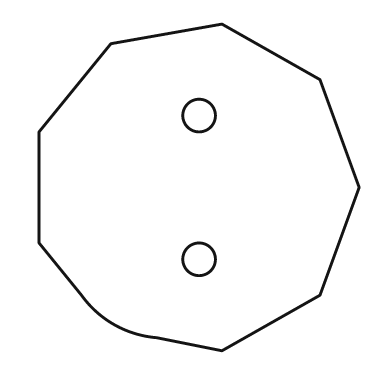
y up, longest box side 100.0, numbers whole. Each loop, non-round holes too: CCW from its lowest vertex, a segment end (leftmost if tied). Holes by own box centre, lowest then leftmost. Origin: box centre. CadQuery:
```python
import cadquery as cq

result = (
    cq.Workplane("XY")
    .moveTo(7.0, -50.0)
    .lineTo(37.0, -33.0)
    .lineTo(49.0, 0.0)
    .lineTo(37.0, 33.0)
    .lineTo(7.0, 50.0)
    .lineTo(-27.0, 44.0)
    .lineTo(-49.0, 17.0)
    .lineTo(-49.0, -17.0)
    .lineTo(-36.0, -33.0)
    .threePointArc((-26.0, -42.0), (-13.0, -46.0))
    .close()
    .moveTo(0.0, -22.0)
    .circle(5.0)
    .moveTo(0.0, 22.0)
    .circle(5.0)
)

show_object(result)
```